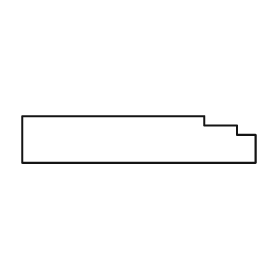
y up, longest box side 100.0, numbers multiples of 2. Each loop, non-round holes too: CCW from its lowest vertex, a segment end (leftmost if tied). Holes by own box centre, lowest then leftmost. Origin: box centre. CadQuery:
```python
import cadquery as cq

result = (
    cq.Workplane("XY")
    .moveTo(-50.0, -10.0)
    .lineTo(50.0, -10.0)
    .lineTo(50.0, 2.0)
    .lineTo(42.0, 2.0)
    .lineTo(42.0, 6.0)
    .lineTo(28.0, 6.0)
    .lineTo(28.0, 10.0)
    .lineTo(-50.0, 10.0)
    .close()
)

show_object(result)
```